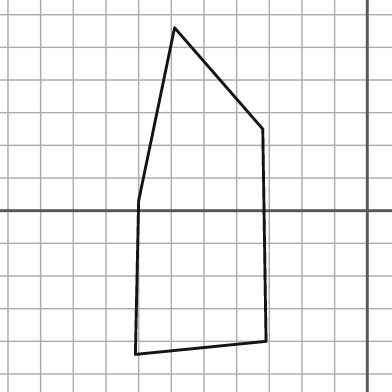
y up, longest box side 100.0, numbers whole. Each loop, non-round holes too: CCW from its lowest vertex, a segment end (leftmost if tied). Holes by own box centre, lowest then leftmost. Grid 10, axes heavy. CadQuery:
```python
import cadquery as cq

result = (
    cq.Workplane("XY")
    .moveTo(-71.0, -44.0)
    .lineTo(-31.0, -40.0)
    .lineTo(-32.0, 25.0)
    .lineTo(-59.0, 56.0)
    .lineTo(-70.0, 3.0)
    .close()
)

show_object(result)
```